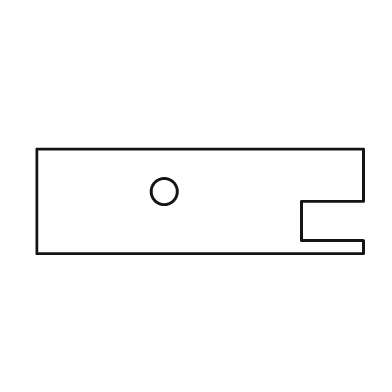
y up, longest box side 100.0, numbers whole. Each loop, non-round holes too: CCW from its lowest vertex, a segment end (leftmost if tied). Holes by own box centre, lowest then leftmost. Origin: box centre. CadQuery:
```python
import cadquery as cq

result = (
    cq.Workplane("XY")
    .moveTo(-50.0, -16.0)
    .lineTo(50.0, -16.0)
    .lineTo(50.0, -12.0)
    .lineTo(31.0, -12.0)
    .lineTo(31.0, 0.0)
    .lineTo(50.0, 0.0)
    .lineTo(50.0, 16.0)
    .lineTo(-50.0, 16.0)
    .close()
    .moveTo(-11.0, 3.0)
    .circle(4.0)
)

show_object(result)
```